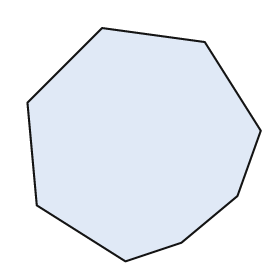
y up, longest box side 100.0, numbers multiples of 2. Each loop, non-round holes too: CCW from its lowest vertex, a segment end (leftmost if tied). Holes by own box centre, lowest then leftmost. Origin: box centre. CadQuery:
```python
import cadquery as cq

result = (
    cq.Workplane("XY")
    .moveTo(-8.0, -50.0)
    .lineTo(16.0, -42.0)
    .lineTo(40.0, -22.0)
    .lineTo(50.0, 6.0)
    .lineTo(26.0, 44.0)
    .lineTo(-18.0, 50.0)
    .lineTo(-50.0, 18.0)
    .lineTo(-46.0, -26.0)
    .close()
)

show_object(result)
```